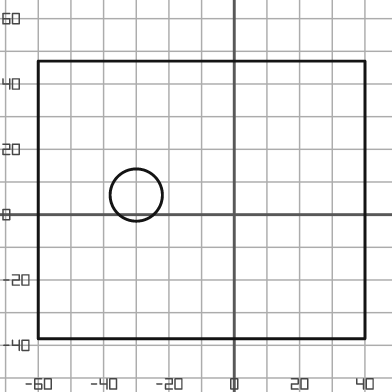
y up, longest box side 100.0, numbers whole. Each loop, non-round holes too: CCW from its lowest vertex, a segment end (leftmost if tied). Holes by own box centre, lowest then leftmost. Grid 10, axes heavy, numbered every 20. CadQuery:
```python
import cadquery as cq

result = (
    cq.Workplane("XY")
    .moveTo(-60.0, -38.0)
    .lineTo(40.0, -38.0)
    .lineTo(40.0, 47.0)
    .lineTo(-60.0, 47.0)
    .close()
    .moveTo(-30.0, 6.0)
    .circle(8.0)
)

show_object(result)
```